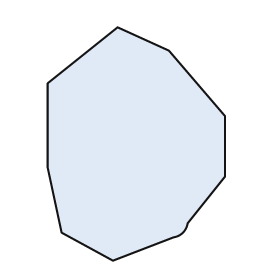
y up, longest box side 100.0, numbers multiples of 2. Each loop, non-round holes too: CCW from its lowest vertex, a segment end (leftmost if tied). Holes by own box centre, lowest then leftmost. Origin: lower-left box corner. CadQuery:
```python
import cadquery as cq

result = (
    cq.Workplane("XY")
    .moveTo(28.0, 0.0)
    .lineTo(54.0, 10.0)
    .threePointArc((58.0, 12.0), (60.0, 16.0))
    .lineTo(76.0, 36.0)
    .lineTo(76.0, 62.0)
    .lineTo(52.0, 90.0)
    .lineTo(30.0, 100.0)
    .lineTo(0.0, 76.0)
    .lineTo(0.0, 40.0)
    .lineTo(6.0, 12.0)
    .close()
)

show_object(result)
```